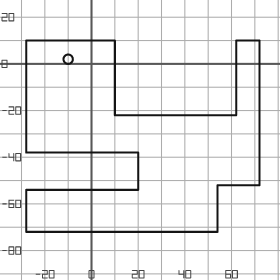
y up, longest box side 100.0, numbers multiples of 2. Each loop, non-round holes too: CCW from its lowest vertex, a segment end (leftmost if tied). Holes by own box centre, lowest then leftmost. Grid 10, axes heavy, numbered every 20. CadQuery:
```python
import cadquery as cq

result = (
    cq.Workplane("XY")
    .moveTo(-28.0, -72.0)
    .lineTo(54.0, -72.0)
    .lineTo(54.0, -52.0)
    .lineTo(72.0, -52.0)
    .lineTo(72.0, 10.0)
    .lineTo(62.0, 10.0)
    .lineTo(62.0, -22.0)
    .lineTo(10.0, -22.0)
    .lineTo(10.0, 10.0)
    .lineTo(-28.0, 10.0)
    .lineTo(-28.0, -38.0)
    .lineTo(20.0, -38.0)
    .lineTo(20.0, -54.0)
    .lineTo(-28.0, -54.0)
    .close()
    .moveTo(-10.0, 2.0)
    .circle(2.0)
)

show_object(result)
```